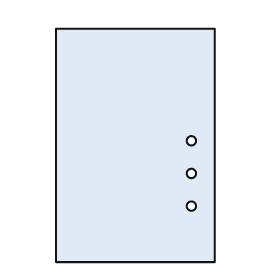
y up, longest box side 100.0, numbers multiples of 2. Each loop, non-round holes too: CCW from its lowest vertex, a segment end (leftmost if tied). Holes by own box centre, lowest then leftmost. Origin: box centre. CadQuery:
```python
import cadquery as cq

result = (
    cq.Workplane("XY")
    .moveTo(-34.0, -50.0)
    .lineTo(34.0, -50.0)
    .lineTo(34.0, 50.0)
    .lineTo(-34.0, 50.0)
    .close()
    .moveTo(24.0, -26.0)
    .circle(2.0)
    .moveTo(24.0, -12.0)
    .circle(2.0)
    .moveTo(24.0, 2.0)
    .circle(2.0)
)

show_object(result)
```